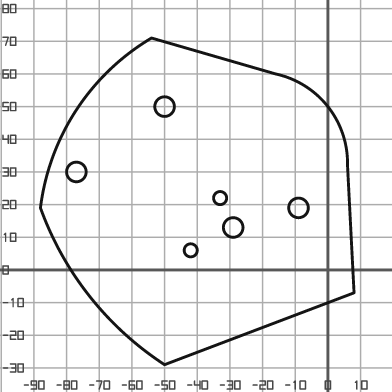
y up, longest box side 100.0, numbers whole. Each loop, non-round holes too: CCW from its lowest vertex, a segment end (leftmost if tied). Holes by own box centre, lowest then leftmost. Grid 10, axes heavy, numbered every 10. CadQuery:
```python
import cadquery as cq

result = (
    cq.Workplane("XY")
    .moveTo(-50.0, -29.0)
    .lineTo(8.0, -7.0)
    .lineTo(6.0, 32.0)
    .threePointArc((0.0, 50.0), (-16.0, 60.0))
    .lineTo(-54.0, 71.0)
    .threePointArc((-77.0, 49.0), (-88.0, 19.0))
    .threePointArc((-73.0, -8.0), (-50.0, -29.0))
    .close()
    .moveTo(-42.0, 6.0)
    .circle(2.0)
    .moveTo(-29.0, 13.0)
    .circle(3.0)
    .moveTo(-9.0, 19.0)
    .circle(3.0)
    .moveTo(-33.0, 22.0)
    .circle(2.0)
    .moveTo(-77.0, 30.0)
    .circle(3.0)
    .moveTo(-50.0, 50.0)
    .circle(3.0)
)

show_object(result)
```